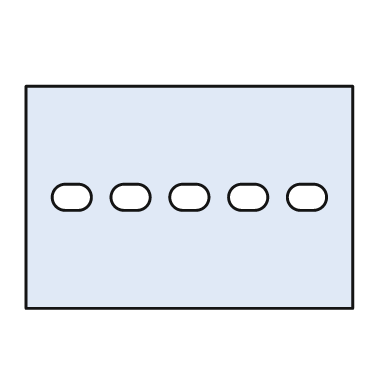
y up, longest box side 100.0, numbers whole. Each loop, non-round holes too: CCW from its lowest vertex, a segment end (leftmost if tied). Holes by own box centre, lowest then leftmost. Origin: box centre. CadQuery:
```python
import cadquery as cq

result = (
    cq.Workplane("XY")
    .moveTo(-50.0, -34.0)
    .lineTo(50.0, -34.0)
    .lineTo(50.0, 34.0)
    .lineTo(-50.0, 34.0)
    .close()
    .moveTo(-38.0, -4.0)
    .lineTo(-34.0, -4.0)
    .threePointArc((-30.0, 0.0), (-34.0, 4.0))
    .lineTo(-38.0, 4.0)
    .threePointArc((-42.0, 0.0), (-38.0, -4.0))
    .close()
    .moveTo(-20.0, -4.0)
    .lineTo(-16.0, -4.0)
    .threePointArc((-12.0, 0.0), (-16.0, 4.0))
    .lineTo(-20.0, 4.0)
    .threePointArc((-24.0, 0.0), (-20.0, -4.0))
    .close()
    .moveTo(-2.0, -4.0)
    .lineTo(2.0, -4.0)
    .threePointArc((6.0, 0.0), (2.0, 4.0))
    .lineTo(-2.0, 4.0)
    .threePointArc((-6.0, 0.0), (-2.0, -4.0))
    .close()
    .moveTo(16.0, -4.0)
    .lineTo(20.0, -4.0)
    .threePointArc((24.0, 0.0), (20.0, 4.0))
    .lineTo(16.0, 4.0)
    .threePointArc((12.0, 0.0), (16.0, -4.0))
    .close()
    .moveTo(34.0, -4.0)
    .lineTo(38.0, -4.0)
    .threePointArc((42.0, 0.0), (38.0, 4.0))
    .lineTo(34.0, 4.0)
    .threePointArc((30.0, 0.0), (34.0, -4.0))
    .close()
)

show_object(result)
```